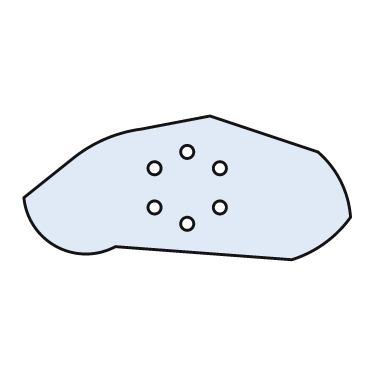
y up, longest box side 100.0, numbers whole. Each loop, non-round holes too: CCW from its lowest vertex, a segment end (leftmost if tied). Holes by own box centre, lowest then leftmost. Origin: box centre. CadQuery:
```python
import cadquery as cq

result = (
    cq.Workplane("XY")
    .moveTo(32.0, -22.0)
    .threePointArc((42.0, -17.0), (50.0, -9.0))
    .threePointArc((47.0, 2.0), (40.0, 11.0))
    .lineTo(7.0, 22.0)
    .lineTo(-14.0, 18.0)
    .threePointArc((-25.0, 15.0), (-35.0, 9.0))
    .lineTo(-50.0, -3.0)
    .threePointArc((-40.0, -18.0), (-22.0, -18.0))
    .close()
    .moveTo(0.0, -11.0)
    .circle(2.0)
    .moveTo(-10.0, -6.0)
    .circle(2.0)
    .moveTo(10.0, -6.0)
    .circle(2.0)
    .moveTo(-10.0, 6.0)
    .circle(2.0)
    .moveTo(10.0, 6.0)
    .circle(2.0)
    .moveTo(0.0, 11.0)
    .circle(2.0)
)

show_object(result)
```